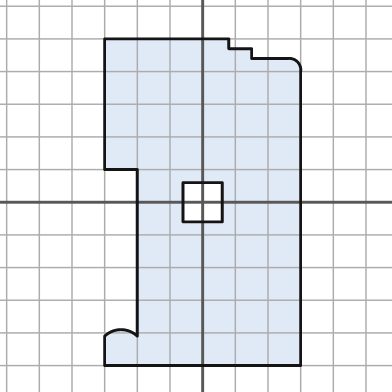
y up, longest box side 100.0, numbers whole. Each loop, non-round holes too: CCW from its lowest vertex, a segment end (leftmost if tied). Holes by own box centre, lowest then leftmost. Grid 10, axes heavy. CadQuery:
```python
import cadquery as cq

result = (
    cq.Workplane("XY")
    .moveTo(-30.0, -50.0)
    .lineTo(30.0, -50.0)
    .lineTo(30.0, 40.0)
    .threePointArc((29.0, 43.0), (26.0, 44.0))
    .lineTo(15.0, 44.0)
    .lineTo(15.0, 47.0)
    .lineTo(8.0, 47.0)
    .lineTo(8.0, 50.0)
    .lineTo(-30.0, 50.0)
    .lineTo(-30.0, 10.0)
    .lineTo(-20.0, 10.0)
    .lineTo(-20.0, -41.0)
    .threePointArc((-25.0, -39.0), (-30.0, -41.0))
    .close()
    .moveTo(-6.0, -6.0)
    .lineTo(6.0, -6.0)
    .lineTo(6.0, 6.0)
    .lineTo(-6.0, 6.0)
    .close()
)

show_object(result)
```